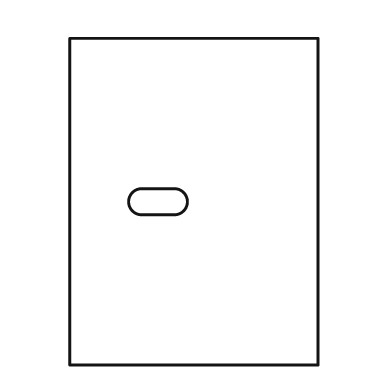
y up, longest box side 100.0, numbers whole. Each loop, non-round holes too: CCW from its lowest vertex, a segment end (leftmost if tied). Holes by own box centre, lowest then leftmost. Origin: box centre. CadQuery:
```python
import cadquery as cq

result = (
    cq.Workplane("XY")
    .moveTo(-38.0, -50.0)
    .lineTo(38.0, -50.0)
    .lineTo(38.0, 50.0)
    .lineTo(-38.0, 50.0)
    .close()
    .moveTo(-16.0, -4.0)
    .lineTo(-6.0, -4.0)
    .threePointArc((-2.0, 0.0), (-6.0, 4.0))
    .lineTo(-16.0, 4.0)
    .threePointArc((-20.0, 0.0), (-16.0, -4.0))
    .close()
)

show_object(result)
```